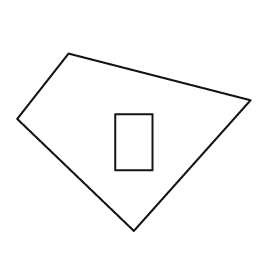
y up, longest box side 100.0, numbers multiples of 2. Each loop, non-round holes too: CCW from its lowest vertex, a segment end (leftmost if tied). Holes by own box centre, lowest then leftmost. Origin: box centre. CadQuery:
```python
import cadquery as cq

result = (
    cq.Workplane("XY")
    .moveTo(0.0, -38.0)
    .lineTo(50.0, 18.0)
    .lineTo(-28.0, 38.0)
    .lineTo(-50.0, 10.0)
    .close()
    .moveTo(-8.0, -12.0)
    .lineTo(8.0, -12.0)
    .lineTo(8.0, 12.0)
    .lineTo(-8.0, 12.0)
    .close()
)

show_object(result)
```